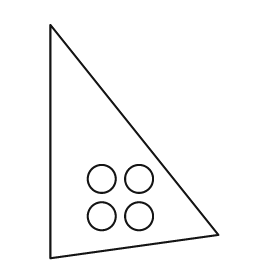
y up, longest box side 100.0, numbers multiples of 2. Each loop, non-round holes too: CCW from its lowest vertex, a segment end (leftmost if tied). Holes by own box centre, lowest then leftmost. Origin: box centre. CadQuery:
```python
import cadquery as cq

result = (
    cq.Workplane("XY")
    .moveTo(-36.0, -50.0)
    .lineTo(36.0, -40.0)
    .lineTo(-36.0, 50.0)
    .close()
    .moveTo(-14.0, -32.0)
    .circle(6.0)
    .moveTo(2.0, -32.0)
    .circle(6.0)
    .moveTo(-14.0, -16.0)
    .circle(6.0)
    .moveTo(2.0, -16.0)
    .circle(6.0)
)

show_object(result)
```